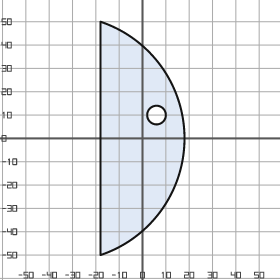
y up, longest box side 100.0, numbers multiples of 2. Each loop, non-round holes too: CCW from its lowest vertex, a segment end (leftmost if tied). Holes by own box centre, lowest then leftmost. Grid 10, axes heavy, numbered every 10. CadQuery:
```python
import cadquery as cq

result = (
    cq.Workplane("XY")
    .moveTo(-18.0, -50.0)
    .threePointArc((18.0, 0.0), (-18.0, 50.0))
    .close()
    .moveTo(6.0, 10.0)
    .circle(4.0)
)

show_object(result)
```